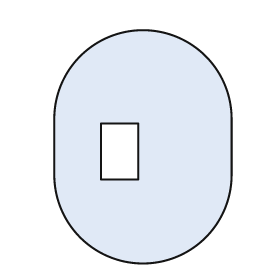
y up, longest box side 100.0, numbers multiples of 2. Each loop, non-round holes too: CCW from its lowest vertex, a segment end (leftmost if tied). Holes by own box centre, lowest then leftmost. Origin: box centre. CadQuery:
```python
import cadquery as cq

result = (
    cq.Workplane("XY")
    .moveTo(-38.0, -12.0)
    .threePointArc((0.0, -50.0), (38.0, -12.0))
    .lineTo(38.0, 12.0)
    .threePointArc((0.0, 50.0), (-38.0, 12.0))
    .close()
    .moveTo(-18.0, -14.0)
    .lineTo(-2.0, -14.0)
    .lineTo(-2.0, 10.0)
    .lineTo(-18.0, 10.0)
    .close()
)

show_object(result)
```